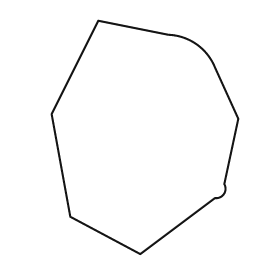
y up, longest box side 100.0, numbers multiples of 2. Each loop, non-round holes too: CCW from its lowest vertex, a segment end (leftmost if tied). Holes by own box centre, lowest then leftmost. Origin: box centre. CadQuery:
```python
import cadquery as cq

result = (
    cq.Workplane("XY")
    .moveTo(-2.0, -50.0)
    .lineTo(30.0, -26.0)
    .threePointArc((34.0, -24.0), (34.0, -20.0))
    .lineTo(40.0, 8.0)
    .lineTo(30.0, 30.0)
    .threePointArc((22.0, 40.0), (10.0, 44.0))
    .lineTo(-20.0, 50.0)
    .lineTo(-40.0, 10.0)
    .lineTo(-32.0, -34.0)
    .close()
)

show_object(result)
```